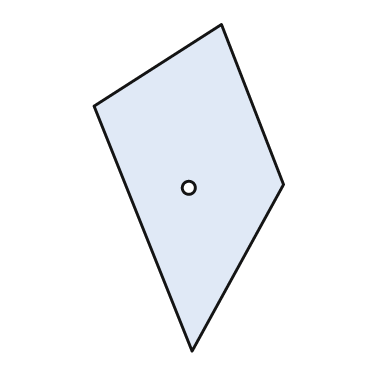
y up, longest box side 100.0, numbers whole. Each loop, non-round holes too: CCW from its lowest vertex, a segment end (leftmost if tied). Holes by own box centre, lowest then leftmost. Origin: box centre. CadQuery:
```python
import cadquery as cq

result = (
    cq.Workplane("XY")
    .moveTo(1.0, -50.0)
    .lineTo(29.0, 1.0)
    .lineTo(10.0, 50.0)
    .lineTo(-29.0, 25.0)
    .close()
    .moveTo(0.0, 0.0)
    .circle(2.0)
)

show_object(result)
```